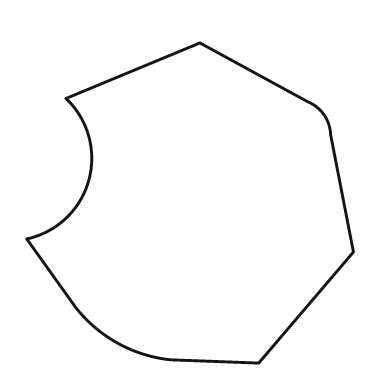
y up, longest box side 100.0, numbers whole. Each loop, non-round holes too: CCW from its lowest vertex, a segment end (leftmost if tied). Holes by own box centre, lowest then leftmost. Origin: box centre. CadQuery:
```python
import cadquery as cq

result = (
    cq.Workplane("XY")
    .moveTo(21.0, -49.0)
    .lineTo(50.0, -15.0)
    .lineTo(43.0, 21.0)
    .threePointArc((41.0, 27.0), (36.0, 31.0))
    .lineTo(3.0, 49.0)
    .lineTo(-38.0, 32.0)
    .threePointArc((-31.0, 7.0), (-50.0, -11.0))
    .lineTo(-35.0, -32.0)
    .threePointArc((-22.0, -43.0), (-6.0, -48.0))
    .close()
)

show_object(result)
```